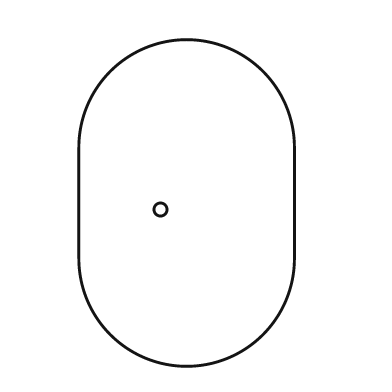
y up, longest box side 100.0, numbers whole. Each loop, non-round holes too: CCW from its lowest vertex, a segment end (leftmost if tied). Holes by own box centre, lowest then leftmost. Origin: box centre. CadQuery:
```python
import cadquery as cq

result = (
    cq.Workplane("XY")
    .moveTo(-33.0, -17.0)
    .threePointArc((0.0, -50.0), (33.0, -17.0))
    .lineTo(33.0, 17.0)
    .threePointArc((0.0, 50.0), (-33.0, 17.0))
    .close()
    .moveTo(-8.0, -2.0)
    .circle(2.0)
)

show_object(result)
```